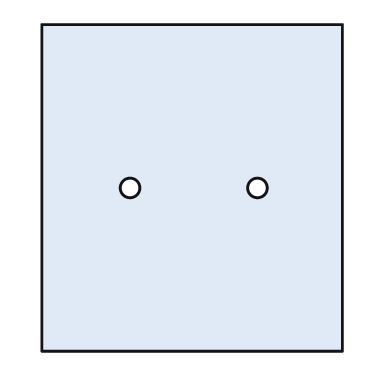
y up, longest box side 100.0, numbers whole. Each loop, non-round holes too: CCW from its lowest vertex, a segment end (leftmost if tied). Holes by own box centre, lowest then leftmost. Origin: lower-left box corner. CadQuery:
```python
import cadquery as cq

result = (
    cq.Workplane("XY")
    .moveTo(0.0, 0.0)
    .lineTo(92.0, 0.0)
    .lineTo(92.0, 100.0)
    .lineTo(0.0, 100.0)
    .close()
    .moveTo(27.0, 50.0)
    .circle(3.0)
    .moveTo(66.0, 50.0)
    .circle(3.0)
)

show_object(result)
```